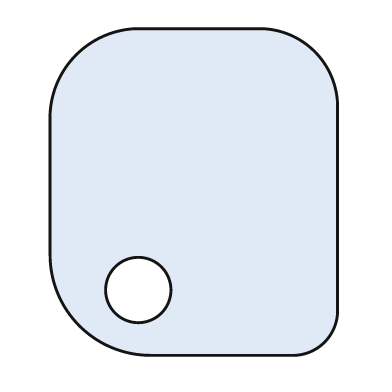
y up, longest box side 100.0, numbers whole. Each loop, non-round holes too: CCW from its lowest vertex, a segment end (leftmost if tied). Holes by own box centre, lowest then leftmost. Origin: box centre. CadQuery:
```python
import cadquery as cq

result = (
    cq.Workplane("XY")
    .moveTo(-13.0, -50.0)
    .lineTo(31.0, -50.0)
    .threePointArc((40.0, -46.0), (44.0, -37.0))
    .lineTo(44.0, 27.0)
    .threePointArc((37.0, 43.0), (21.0, 50.0))
    .lineTo(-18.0, 50.0)
    .threePointArc((-36.0, 42.0), (-44.0, 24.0))
    .lineTo(-44.0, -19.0)
    .threePointArc((-35.0, -41.0), (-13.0, -50.0))
    .close()
    .moveTo(-17.0, -30.0)
    .circle(10.0)
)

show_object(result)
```